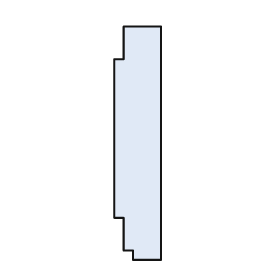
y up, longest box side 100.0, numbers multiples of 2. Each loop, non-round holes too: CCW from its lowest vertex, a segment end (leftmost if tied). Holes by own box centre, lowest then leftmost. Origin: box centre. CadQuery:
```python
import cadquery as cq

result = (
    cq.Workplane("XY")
    .moveTo(-2.0, -50.0)
    .lineTo(10.0, -50.0)
    .lineTo(10.0, 50.0)
    .lineTo(-6.0, 50.0)
    .lineTo(-6.0, 36.0)
    .lineTo(-10.0, 36.0)
    .lineTo(-10.0, -32.0)
    .lineTo(-6.0, -32.0)
    .lineTo(-6.0, -46.0)
    .lineTo(-2.0, -46.0)
    .close()
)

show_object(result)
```